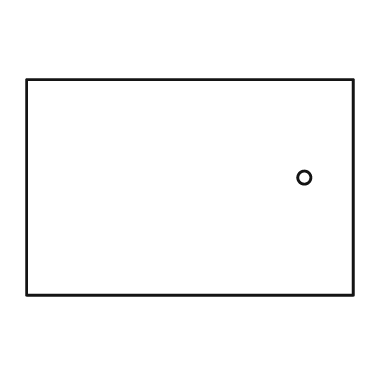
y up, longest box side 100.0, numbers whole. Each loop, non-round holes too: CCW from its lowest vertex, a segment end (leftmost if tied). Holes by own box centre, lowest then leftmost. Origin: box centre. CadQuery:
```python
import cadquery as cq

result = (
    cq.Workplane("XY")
    .moveTo(-50.0, -33.0)
    .lineTo(50.0, -33.0)
    .lineTo(50.0, 33.0)
    .lineTo(-50.0, 33.0)
    .close()
    .moveTo(35.0, 3.0)
    .circle(2.0)
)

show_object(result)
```